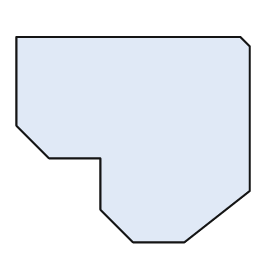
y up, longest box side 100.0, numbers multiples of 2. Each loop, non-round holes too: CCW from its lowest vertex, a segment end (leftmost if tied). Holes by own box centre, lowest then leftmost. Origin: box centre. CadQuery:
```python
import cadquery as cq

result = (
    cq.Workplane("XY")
    .moveTo(0.0, -44.0)
    .lineTo(22.0, -44.0)
    .lineTo(50.0, -22.0)
    .lineTo(50.0, 40.0)
    .lineTo(46.0, 44.0)
    .lineTo(-50.0, 44.0)
    .lineTo(-50.0, 6.0)
    .lineTo(-36.0, -8.0)
    .lineTo(-14.0, -8.0)
    .lineTo(-14.0, -30.0)
    .close()
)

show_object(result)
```